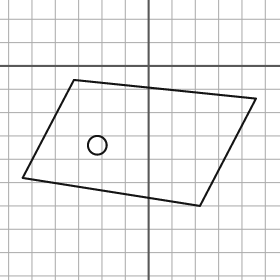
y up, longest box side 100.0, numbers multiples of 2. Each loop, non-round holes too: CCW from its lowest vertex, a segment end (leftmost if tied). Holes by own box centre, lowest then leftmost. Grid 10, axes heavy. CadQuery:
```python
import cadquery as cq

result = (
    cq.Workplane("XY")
    .moveTo(22.0, -60.0)
    .lineTo(46.0, -14.0)
    .lineTo(-32.0, -6.0)
    .lineTo(-54.0, -48.0)
    .close()
    .moveTo(-22.0, -34.0)
    .circle(4.0)
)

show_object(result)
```